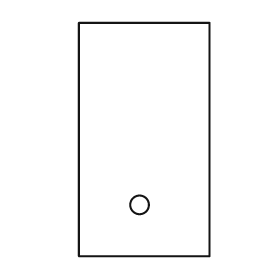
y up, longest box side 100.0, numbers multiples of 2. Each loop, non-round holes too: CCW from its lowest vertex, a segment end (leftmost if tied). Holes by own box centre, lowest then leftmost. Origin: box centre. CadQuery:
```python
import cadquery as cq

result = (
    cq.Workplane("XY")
    .moveTo(-28.0, -50.0)
    .lineTo(28.0, -50.0)
    .lineTo(28.0, 50.0)
    .lineTo(-28.0, 50.0)
    .close()
    .moveTo(-2.0, -28.0)
    .circle(4.0)
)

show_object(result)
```